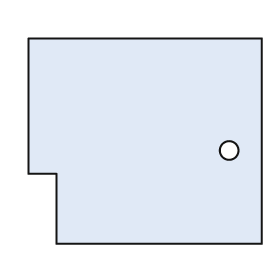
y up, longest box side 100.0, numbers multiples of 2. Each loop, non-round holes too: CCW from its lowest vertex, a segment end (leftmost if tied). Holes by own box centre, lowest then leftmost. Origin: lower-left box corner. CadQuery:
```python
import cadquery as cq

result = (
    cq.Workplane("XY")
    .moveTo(12.0, 0.0)
    .lineTo(100.0, 0.0)
    .lineTo(100.0, 88.0)
    .lineTo(0.0, 88.0)
    .lineTo(0.0, 30.0)
    .lineTo(12.0, 30.0)
    .close()
    .moveTo(86.0, 40.0)
    .circle(4.0)
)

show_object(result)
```